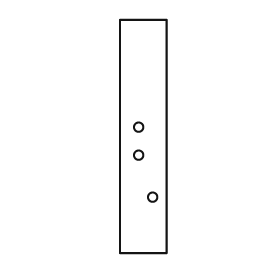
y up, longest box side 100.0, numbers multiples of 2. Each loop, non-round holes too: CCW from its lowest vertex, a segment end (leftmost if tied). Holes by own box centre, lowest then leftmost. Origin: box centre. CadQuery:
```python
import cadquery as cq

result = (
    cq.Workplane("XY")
    .moveTo(-10.0, -50.0)
    .lineTo(10.0, -50.0)
    .lineTo(10.0, 50.0)
    .lineTo(-10.0, 50.0)
    .close()
    .moveTo(4.0, -26.0)
    .circle(2.0)
    .moveTo(-2.0, -8.0)
    .circle(2.0)
    .moveTo(-2.0, 4.0)
    .circle(2.0)
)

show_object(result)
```